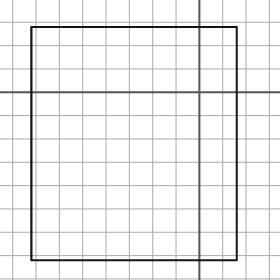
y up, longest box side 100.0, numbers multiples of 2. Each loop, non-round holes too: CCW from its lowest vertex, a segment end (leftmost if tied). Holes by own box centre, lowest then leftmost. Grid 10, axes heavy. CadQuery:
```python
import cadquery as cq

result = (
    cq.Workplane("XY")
    .moveTo(-72.0, -72.0)
    .lineTo(16.0, -72.0)
    .lineTo(16.0, 28.0)
    .lineTo(-72.0, 28.0)
    .close()
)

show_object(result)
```